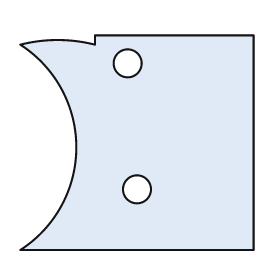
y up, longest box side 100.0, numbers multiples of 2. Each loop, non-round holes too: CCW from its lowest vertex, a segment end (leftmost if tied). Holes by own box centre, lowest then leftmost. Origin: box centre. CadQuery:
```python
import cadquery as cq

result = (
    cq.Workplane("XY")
    .moveTo(-50.0, -46.0)
    .lineTo(50.0, -46.0)
    .lineTo(50.0, 46.0)
    .lineTo(-18.0, 46.0)
    .lineTo(-18.0, 42.0)
    .threePointArc((-34.0, 44.0), (-50.0, 42.0))
    .threePointArc((-26.0, -2.0), (-50.0, -46.0))
    .close()
    .moveTo(0.0, -20.0)
    .circle(6.0)
    .moveTo(-4.0, 34.0)
    .circle(6.0)
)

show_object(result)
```